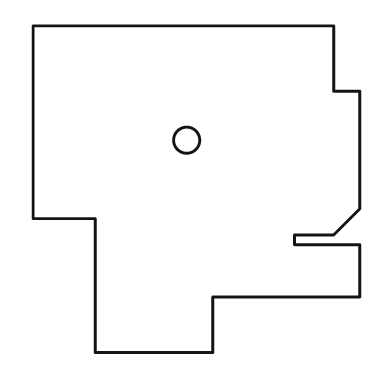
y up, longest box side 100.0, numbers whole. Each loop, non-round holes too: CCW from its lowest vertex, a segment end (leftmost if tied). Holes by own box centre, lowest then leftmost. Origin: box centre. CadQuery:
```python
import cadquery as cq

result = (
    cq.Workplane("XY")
    .moveTo(-31.0, -50.0)
    .lineTo(5.0, -50.0)
    .lineTo(5.0, -33.0)
    .lineTo(50.0, -33.0)
    .lineTo(50.0, -17.0)
    .lineTo(30.0, -17.0)
    .lineTo(30.0, -14.0)
    .lineTo(42.0, -14.0)
    .lineTo(50.0, -6.0)
    .lineTo(50.0, 30.0)
    .lineTo(42.0, 30.0)
    .lineTo(42.0, 50.0)
    .lineTo(-50.0, 50.0)
    .lineTo(-50.0, -9.0)
    .lineTo(-31.0, -9.0)
    .close()
    .moveTo(-3.0, 15.0)
    .circle(4.0)
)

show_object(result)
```